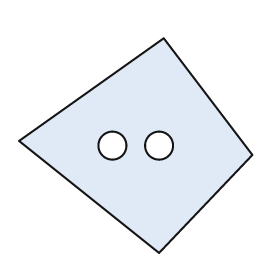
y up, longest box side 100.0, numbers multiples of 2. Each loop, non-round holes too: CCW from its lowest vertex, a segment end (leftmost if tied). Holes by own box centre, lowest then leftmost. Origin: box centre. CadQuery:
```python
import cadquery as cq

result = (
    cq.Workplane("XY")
    .moveTo(10.0, -46.0)
    .lineTo(50.0, -4.0)
    .lineTo(12.0, 46.0)
    .lineTo(-50.0, 2.0)
    .close()
    .moveTo(-10.0, 0.0)
    .circle(6.0)
    .moveTo(10.0, 0.0)
    .circle(6.0)
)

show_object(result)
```